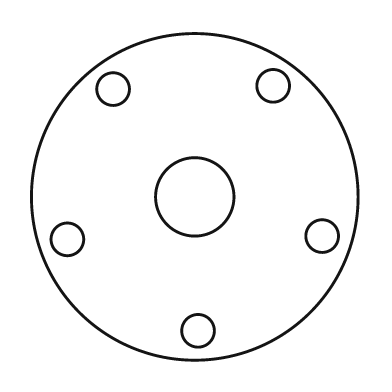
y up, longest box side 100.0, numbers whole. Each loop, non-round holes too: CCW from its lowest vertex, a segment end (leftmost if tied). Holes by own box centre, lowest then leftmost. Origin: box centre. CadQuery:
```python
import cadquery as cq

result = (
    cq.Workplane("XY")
    .moveTo(0.0, 0.0)
    .circle(50.0)
    .moveTo(1.0, -41.0)
    .circle(5.0)
    .moveTo(-39.0, -13.0)
    .circle(5.0)
    .moveTo(39.0, -12.0)
    .circle(5.0)
    .moveTo(0.0, 0.0)
    .circle(12.0)
    .moveTo(-25.0, 33.0)
    .circle(5.0)
    .moveTo(24.0, 34.0)
    .circle(5.0)
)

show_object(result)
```